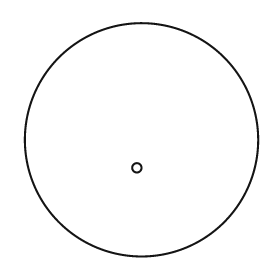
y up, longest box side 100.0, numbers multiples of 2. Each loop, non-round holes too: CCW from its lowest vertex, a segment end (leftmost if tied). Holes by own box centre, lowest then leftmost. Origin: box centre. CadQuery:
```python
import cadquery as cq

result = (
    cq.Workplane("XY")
    .moveTo(0.0, 0.0)
    .circle(50.0)
    .moveTo(-2.0, -12.0)
    .circle(2.0)
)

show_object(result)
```